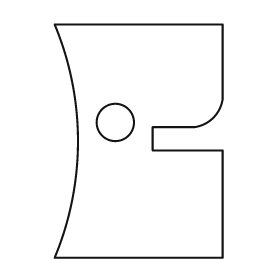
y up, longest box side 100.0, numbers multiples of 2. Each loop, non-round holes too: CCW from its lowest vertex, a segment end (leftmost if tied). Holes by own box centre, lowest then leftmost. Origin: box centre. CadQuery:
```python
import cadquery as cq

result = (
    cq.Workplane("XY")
    .moveTo(-36.0, -50.0)
    .lineTo(36.0, -50.0)
    .lineTo(36.0, -4.0)
    .lineTo(6.0, -4.0)
    .lineTo(6.0, 6.0)
    .lineTo(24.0, 6.0)
    .threePointArc((32.0, 10.0), (36.0, 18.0))
    .lineTo(36.0, 50.0)
    .lineTo(-36.0, 50.0)
    .threePointArc((-26.0, 0.0), (-36.0, -50.0))
    .close()
    .moveTo(-10.0, 8.0)
    .circle(8.0)
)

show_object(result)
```